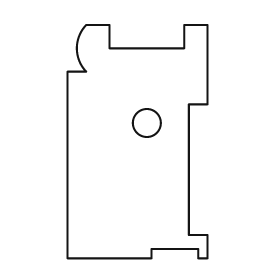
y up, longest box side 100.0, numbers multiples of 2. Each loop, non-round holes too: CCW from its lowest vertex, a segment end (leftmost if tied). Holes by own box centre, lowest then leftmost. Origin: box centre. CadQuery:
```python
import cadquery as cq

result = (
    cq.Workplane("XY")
    .moveTo(-30.0, -50.0)
    .lineTo(6.0, -50.0)
    .lineTo(6.0, -46.0)
    .lineTo(26.0, -46.0)
    .lineTo(26.0, -50.0)
    .lineTo(30.0, -50.0)
    .lineTo(30.0, -40.0)
    .lineTo(22.0, -40.0)
    .lineTo(22.0, 16.0)
    .lineTo(30.0, 16.0)
    .lineTo(30.0, 50.0)
    .lineTo(20.0, 50.0)
    .lineTo(20.0, 40.0)
    .lineTo(-12.0, 40.0)
    .lineTo(-12.0, 50.0)
    .lineTo(-22.0, 50.0)
    .threePointArc((-26.0, 40.0), (-22.0, 30.0))
    .lineTo(-30.0, 30.0)
    .close()
    .moveTo(4.0, 8.0)
    .circle(6.0)
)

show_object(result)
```